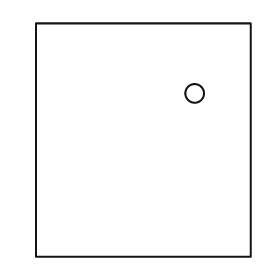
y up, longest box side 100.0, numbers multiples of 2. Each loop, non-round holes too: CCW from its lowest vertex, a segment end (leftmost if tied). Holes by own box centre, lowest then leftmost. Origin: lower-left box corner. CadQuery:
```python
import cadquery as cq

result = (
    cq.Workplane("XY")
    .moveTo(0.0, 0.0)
    .lineTo(92.0, 0.0)
    .lineTo(92.0, 100.0)
    .lineTo(0.0, 100.0)
    .close()
    .moveTo(68.0, 70.0)
    .circle(4.0)
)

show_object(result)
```